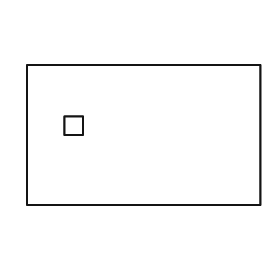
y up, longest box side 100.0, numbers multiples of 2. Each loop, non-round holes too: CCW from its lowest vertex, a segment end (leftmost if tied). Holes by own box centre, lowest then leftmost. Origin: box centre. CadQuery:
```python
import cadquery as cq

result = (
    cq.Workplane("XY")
    .moveTo(-50.0, -30.0)
    .lineTo(50.0, -30.0)
    .lineTo(50.0, 30.0)
    .lineTo(-50.0, 30.0)
    .close()
    .moveTo(-34.0, 0.0)
    .lineTo(-26.0, 0.0)
    .lineTo(-26.0, 8.0)
    .lineTo(-34.0, 8.0)
    .close()
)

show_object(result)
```